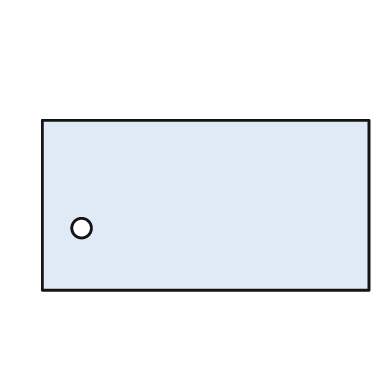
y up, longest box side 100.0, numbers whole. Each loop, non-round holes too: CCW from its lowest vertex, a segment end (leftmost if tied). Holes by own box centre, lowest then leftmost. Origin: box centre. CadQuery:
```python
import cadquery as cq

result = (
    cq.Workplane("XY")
    .moveTo(-50.0, -26.0)
    .lineTo(50.0, -26.0)
    .lineTo(50.0, 26.0)
    .lineTo(-50.0, 26.0)
    .close()
    .moveTo(-38.0, -7.0)
    .circle(3.0)
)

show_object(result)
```